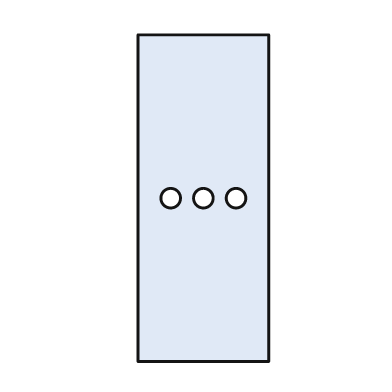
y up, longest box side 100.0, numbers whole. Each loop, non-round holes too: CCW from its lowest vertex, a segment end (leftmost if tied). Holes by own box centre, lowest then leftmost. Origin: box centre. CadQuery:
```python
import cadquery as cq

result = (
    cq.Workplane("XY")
    .moveTo(-20.0, -50.0)
    .lineTo(20.0, -50.0)
    .lineTo(20.0, 50.0)
    .lineTo(-20.0, 50.0)
    .close()
    .moveTo(-10.0, 0.0)
    .circle(3.0)
    .moveTo(0.0, 0.0)
    .circle(3.0)
    .moveTo(10.0, 0.0)
    .circle(3.0)
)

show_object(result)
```